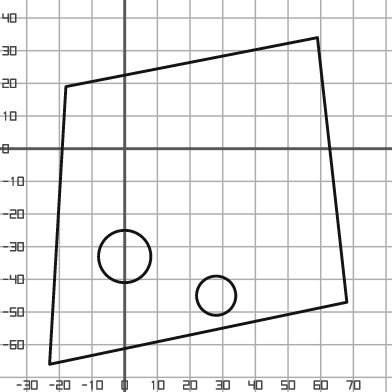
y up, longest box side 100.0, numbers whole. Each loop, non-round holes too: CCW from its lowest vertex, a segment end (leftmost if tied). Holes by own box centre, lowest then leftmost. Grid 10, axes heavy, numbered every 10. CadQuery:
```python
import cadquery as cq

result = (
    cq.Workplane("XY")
    .moveTo(-23.0, -66.0)
    .lineTo(68.0, -47.0)
    .lineTo(59.0, 34.0)
    .lineTo(-18.0, 19.0)
    .close()
    .moveTo(28.0, -45.0)
    .circle(6.0)
    .moveTo(0.0, -33.0)
    .circle(8.0)
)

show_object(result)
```